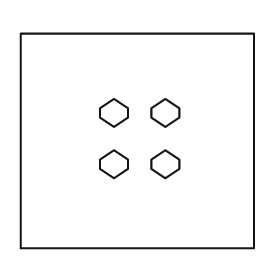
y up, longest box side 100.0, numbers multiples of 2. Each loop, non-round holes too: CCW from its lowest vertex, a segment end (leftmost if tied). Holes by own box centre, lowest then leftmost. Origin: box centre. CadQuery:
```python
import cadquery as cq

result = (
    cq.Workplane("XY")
    .moveTo(-50.0, -46.0)
    .lineTo(50.0, -46.0)
    .lineTo(50.0, 46.0)
    .lineTo(-50.0, 46.0)
    .close()
    .moveTo(-10.0, -16.0)
    .lineTo(-4.0, -12.0)
    .lineTo(-4.0, -8.0)
    .lineTo(-10.0, -4.0)
    .lineTo(-16.0, -8.0)
    .lineTo(-16.0, -12.0)
    .close()
    .moveTo(12.0, -16.0)
    .lineTo(18.0, -12.0)
    .lineTo(18.0, -8.0)
    .lineTo(12.0, -4.0)
    .lineTo(6.0, -8.0)
    .lineTo(6.0, -12.0)
    .close()
    .moveTo(-10.0, 6.0)
    .lineTo(-4.0, 10.0)
    .lineTo(-4.0, 14.0)
    .lineTo(-10.0, 18.0)
    .lineTo(-16.0, 14.0)
    .lineTo(-16.0, 10.0)
    .close()
    .moveTo(12.0, 6.0)
    .lineTo(18.0, 10.0)
    .lineTo(18.0, 14.0)
    .lineTo(12.0, 18.0)
    .lineTo(6.0, 14.0)
    .lineTo(6.0, 10.0)
    .close()
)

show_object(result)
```